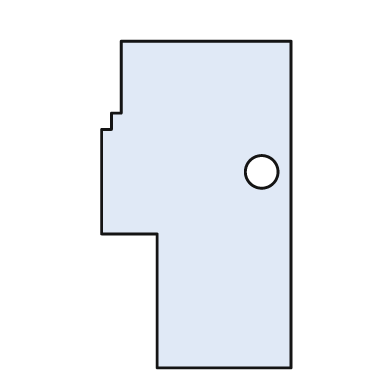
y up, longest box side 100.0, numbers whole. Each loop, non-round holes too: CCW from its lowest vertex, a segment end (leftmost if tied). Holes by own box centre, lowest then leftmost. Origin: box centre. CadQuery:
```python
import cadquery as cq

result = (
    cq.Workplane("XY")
    .moveTo(-12.0, -50.0)
    .lineTo(29.0, -50.0)
    .lineTo(29.0, 50.0)
    .lineTo(-23.0, 50.0)
    .lineTo(-23.0, 28.0)
    .lineTo(-26.0, 28.0)
    .lineTo(-26.0, 23.0)
    .lineTo(-29.0, 23.0)
    .lineTo(-29.0, -9.0)
    .lineTo(-12.0, -9.0)
    .close()
    .moveTo(20.0, 10.0)
    .circle(5.0)
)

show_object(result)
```